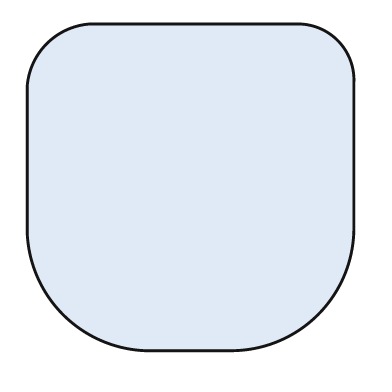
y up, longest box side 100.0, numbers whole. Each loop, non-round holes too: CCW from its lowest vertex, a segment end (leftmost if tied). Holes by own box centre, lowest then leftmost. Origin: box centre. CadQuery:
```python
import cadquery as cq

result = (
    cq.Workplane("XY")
    .moveTo(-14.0, -50.0)
    .lineTo(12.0, -50.0)
    .threePointArc((39.0, -39.0), (50.0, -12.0))
    .lineTo(50.0, 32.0)
    .threePointArc((45.0, 45.0), (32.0, 50.0))
    .lineTo(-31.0, 50.0)
    .threePointArc((-44.0, 44.0), (-50.0, 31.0))
    .lineTo(-50.0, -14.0)
    .threePointArc((-39.0, -39.0), (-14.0, -50.0))
    .close()
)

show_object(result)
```